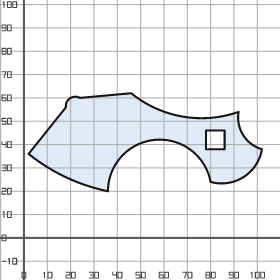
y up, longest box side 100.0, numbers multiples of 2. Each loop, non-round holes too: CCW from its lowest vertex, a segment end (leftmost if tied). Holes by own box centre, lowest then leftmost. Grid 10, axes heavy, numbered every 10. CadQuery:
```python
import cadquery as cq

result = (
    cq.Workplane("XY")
    .moveTo(36.0, 20.0)
    .threePointArc((56.0, 42.0), (80.0, 24.0))
    .threePointArc((94.0, 26.0), (102.0, 38.0))
    .threePointArc((94.0, 44.0), (92.0, 54.0))
    .threePointArc((68.0, 52.0), (46.0, 62.0))
    .lineTo(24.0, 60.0)
    .threePointArc((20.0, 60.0), (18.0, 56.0))
    .lineTo(2.0, 36.0)
    .threePointArc((18.0, 26.0), (36.0, 20.0))
    .close()
    .moveTo(78.0, 38.0)
    .lineTo(86.0, 38.0)
    .lineTo(86.0, 46.0)
    .lineTo(78.0, 46.0)
    .close()
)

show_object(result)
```